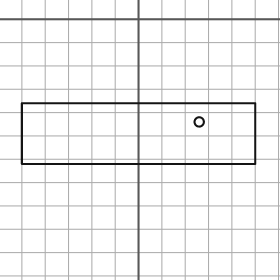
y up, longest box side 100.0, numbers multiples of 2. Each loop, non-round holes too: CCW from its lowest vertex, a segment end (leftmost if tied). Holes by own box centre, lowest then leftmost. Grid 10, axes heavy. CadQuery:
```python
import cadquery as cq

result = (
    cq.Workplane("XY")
    .moveTo(-50.0, -62.0)
    .lineTo(50.0, -62.0)
    .lineTo(50.0, -36.0)
    .lineTo(-50.0, -36.0)
    .close()
    .moveTo(26.0, -44.0)
    .circle(2.0)
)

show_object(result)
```